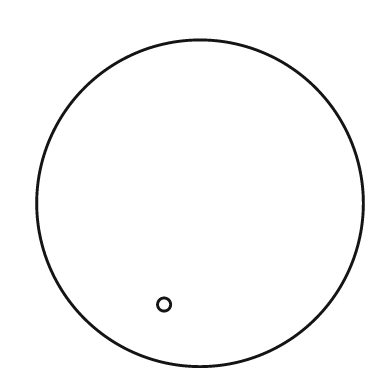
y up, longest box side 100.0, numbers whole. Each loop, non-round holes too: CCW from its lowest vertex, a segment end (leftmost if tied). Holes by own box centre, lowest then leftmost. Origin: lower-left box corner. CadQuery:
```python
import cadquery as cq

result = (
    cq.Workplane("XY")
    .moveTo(50.0, 50.0)
    .circle(50.0)
    .moveTo(39.0, 19.0)
    .circle(2.0)
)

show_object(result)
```